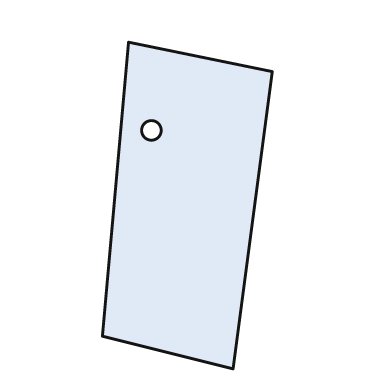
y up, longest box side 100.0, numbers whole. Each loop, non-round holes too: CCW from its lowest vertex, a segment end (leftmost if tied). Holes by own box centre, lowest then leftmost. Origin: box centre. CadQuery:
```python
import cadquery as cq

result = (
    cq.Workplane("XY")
    .moveTo(14.0, -50.0)
    .lineTo(26.0, 41.0)
    .lineTo(-18.0, 50.0)
    .lineTo(-26.0, -40.0)
    .close()
    .moveTo(-11.0, 23.0)
    .circle(3.0)
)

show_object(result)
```